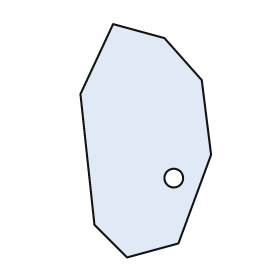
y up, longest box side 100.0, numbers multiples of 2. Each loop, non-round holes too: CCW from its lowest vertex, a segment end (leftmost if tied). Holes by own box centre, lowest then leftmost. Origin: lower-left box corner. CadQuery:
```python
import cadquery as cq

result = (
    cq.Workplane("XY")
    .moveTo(20.0, 0.0)
    .lineTo(42.0, 6.0)
    .lineTo(56.0, 44.0)
    .lineTo(52.0, 76.0)
    .lineTo(36.0, 94.0)
    .lineTo(14.0, 100.0)
    .lineTo(0.0, 70.0)
    .lineTo(6.0, 14.0)
    .close()
    .moveTo(40.0, 34.0)
    .circle(4.0)
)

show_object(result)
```